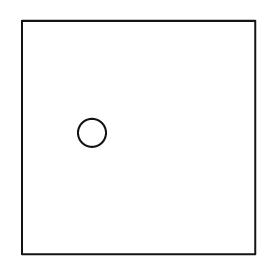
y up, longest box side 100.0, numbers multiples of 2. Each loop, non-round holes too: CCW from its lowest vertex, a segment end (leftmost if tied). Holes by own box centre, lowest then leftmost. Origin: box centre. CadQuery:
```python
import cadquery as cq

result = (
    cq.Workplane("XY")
    .moveTo(-50.0, -50.0)
    .lineTo(50.0, -50.0)
    .lineTo(50.0, 50.0)
    .lineTo(-50.0, 50.0)
    .close()
    .moveTo(-20.0, 2.0)
    .circle(6.0)
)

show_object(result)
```